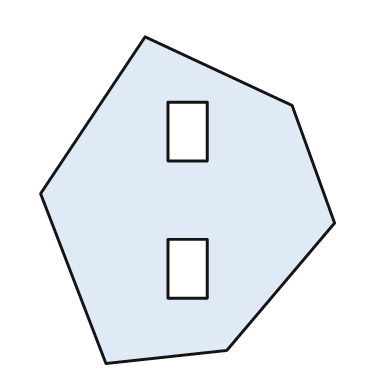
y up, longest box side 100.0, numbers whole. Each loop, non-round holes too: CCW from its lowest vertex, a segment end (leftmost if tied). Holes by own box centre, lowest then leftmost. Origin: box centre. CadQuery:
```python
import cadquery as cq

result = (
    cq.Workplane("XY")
    .moveTo(-25.0, -50.0)
    .lineTo(12.0, -46.0)
    .lineTo(45.0, -7.0)
    .lineTo(32.0, 29.0)
    .lineTo(-13.0, 50.0)
    .lineTo(-45.0, 2.0)
    .close()
    .moveTo(-6.0, -30.0)
    .lineTo(6.0, -30.0)
    .lineTo(6.0, -12.0)
    .lineTo(-6.0, -12.0)
    .close()
    .moveTo(-6.0, 12.0)
    .lineTo(6.0, 12.0)
    .lineTo(6.0, 30.0)
    .lineTo(-6.0, 30.0)
    .close()
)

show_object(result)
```